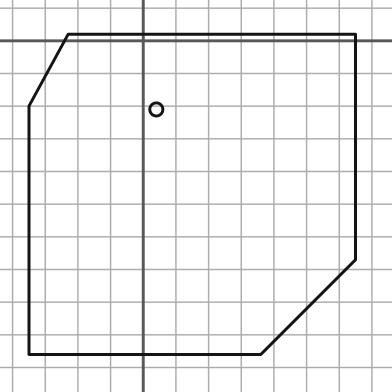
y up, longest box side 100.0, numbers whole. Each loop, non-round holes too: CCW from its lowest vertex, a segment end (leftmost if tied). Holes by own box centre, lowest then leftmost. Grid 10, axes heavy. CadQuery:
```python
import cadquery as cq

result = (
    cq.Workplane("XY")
    .moveTo(-35.0, -96.0)
    .lineTo(36.0, -96.0)
    .lineTo(65.0, -67.0)
    .lineTo(65.0, 2.0)
    .lineTo(-23.0, 2.0)
    .lineTo(-35.0, -20.0)
    .close()
    .moveTo(4.0, -21.0)
    .circle(2.0)
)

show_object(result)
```